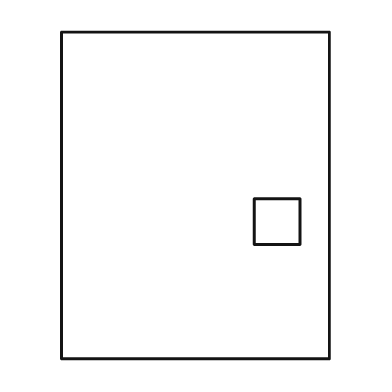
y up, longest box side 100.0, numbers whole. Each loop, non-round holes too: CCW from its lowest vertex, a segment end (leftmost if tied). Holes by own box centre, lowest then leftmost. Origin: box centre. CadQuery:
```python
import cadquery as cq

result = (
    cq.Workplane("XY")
    .moveTo(-41.0, -50.0)
    .lineTo(41.0, -50.0)
    .lineTo(41.0, 50.0)
    .lineTo(-41.0, 50.0)
    .close()
    .moveTo(18.0, -15.0)
    .lineTo(32.0, -15.0)
    .lineTo(32.0, -1.0)
    .lineTo(18.0, -1.0)
    .close()
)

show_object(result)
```